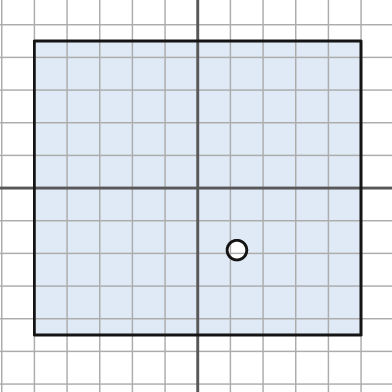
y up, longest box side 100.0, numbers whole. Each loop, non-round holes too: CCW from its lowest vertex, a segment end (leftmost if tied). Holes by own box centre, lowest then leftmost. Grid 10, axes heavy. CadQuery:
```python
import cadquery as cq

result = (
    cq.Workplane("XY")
    .moveTo(-50.0, -45.0)
    .lineTo(50.0, -45.0)
    .lineTo(50.0, 45.0)
    .lineTo(-50.0, 45.0)
    .close()
    .moveTo(12.0, -19.0)
    .circle(3.0)
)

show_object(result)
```